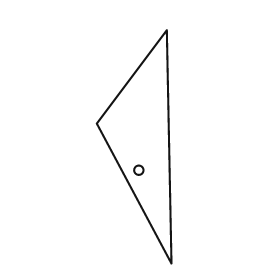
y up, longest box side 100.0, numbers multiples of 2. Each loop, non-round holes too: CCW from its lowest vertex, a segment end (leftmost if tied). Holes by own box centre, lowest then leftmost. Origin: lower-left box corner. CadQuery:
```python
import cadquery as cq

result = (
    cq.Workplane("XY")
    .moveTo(32.0, 0.0)
    .lineTo(30.0, 100.0)
    .lineTo(0.0, 60.0)
    .close()
    .moveTo(18.0, 40.0)
    .circle(2.0)
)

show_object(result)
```